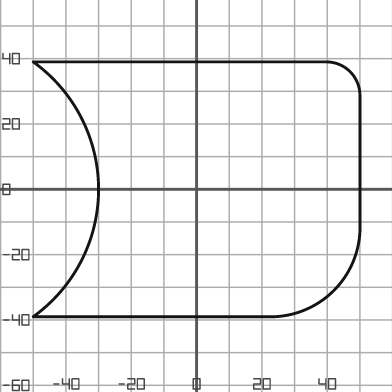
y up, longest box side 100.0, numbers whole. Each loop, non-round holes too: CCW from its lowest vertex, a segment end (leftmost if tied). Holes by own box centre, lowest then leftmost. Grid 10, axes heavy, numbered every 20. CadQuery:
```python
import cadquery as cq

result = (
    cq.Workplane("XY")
    .moveTo(-50.0, -39.0)
    .lineTo(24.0, -39.0)
    .threePointArc((42.0, -31.0), (50.0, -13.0))
    .lineTo(50.0, 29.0)
    .threePointArc((47.0, 36.0), (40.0, 39.0))
    .lineTo(-50.0, 39.0)
    .threePointArc((-30.0, 0.0), (-50.0, -39.0))
    .close()
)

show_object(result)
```